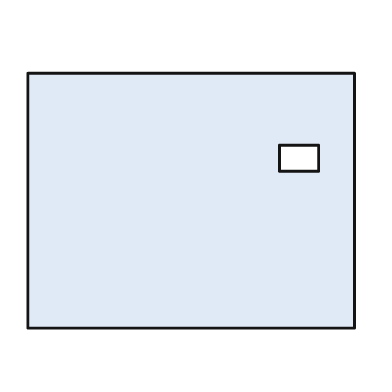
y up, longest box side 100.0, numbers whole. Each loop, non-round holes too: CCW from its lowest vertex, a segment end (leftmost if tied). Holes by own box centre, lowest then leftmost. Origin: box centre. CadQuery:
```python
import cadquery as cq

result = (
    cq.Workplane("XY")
    .moveTo(-50.0, -39.0)
    .lineTo(50.0, -39.0)
    .lineTo(50.0, 39.0)
    .lineTo(-50.0, 39.0)
    .close()
    .moveTo(27.0, 9.0)
    .lineTo(39.0, 9.0)
    .lineTo(39.0, 17.0)
    .lineTo(27.0, 17.0)
    .close()
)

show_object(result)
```